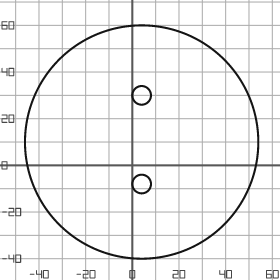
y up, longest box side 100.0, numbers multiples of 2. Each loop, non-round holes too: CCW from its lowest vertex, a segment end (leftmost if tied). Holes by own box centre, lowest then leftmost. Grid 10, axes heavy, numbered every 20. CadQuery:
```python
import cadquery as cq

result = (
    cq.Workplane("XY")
    .moveTo(4.0, 10.0)
    .circle(50.0)
    .moveTo(4.0, -8.0)
    .circle(4.0)
    .moveTo(4.0, 30.0)
    .circle(4.0)
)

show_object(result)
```